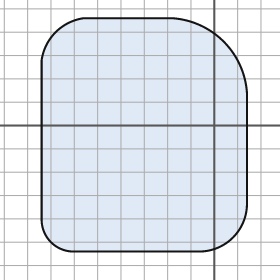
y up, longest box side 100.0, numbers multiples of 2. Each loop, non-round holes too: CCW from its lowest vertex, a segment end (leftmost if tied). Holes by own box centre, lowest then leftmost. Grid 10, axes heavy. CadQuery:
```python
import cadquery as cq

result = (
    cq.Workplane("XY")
    .moveTo(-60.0, -54.0)
    .lineTo(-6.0, -54.0)
    .threePointArc((8.0, -48.0), (14.0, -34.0))
    .lineTo(14.0, 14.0)
    .threePointArc((4.0, 36.0), (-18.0, 46.0))
    .lineTo(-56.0, 46.0)
    .threePointArc((-68.0, 40.0), (-74.0, 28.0))
    .lineTo(-74.0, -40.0)
    .threePointArc((-70.0, -50.0), (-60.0, -54.0))
    .close()
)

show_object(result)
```